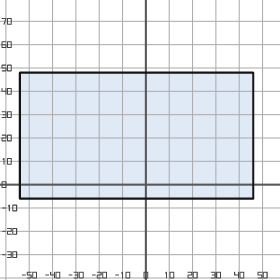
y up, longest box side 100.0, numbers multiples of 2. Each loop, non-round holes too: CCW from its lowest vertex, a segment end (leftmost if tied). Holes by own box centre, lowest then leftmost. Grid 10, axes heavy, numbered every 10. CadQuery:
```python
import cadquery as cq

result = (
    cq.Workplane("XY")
    .moveTo(-54.0, -6.0)
    .lineTo(46.0, -6.0)
    .lineTo(46.0, 48.0)
    .lineTo(-54.0, 48.0)
    .close()
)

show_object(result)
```